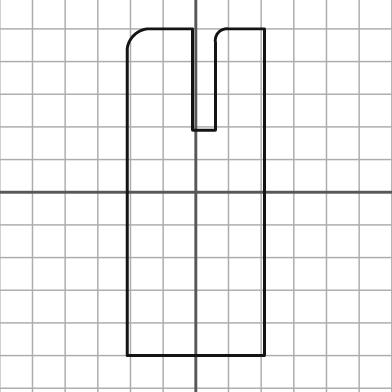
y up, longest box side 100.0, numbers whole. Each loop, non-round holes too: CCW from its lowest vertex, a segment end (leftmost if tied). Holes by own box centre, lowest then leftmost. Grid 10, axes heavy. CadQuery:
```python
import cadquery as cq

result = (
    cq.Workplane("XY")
    .moveTo(-21.0, -50.0)
    .lineTo(21.0, -50.0)
    .lineTo(21.0, 50.0)
    .lineTo(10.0, 50.0)
    .threePointArc((7.0, 49.0), (6.0, 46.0))
    .lineTo(6.0, 19.0)
    .lineTo(-1.0, 19.0)
    .lineTo(-1.0, 50.0)
    .lineTo(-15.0, 50.0)
    .threePointArc((-19.0, 48.0), (-21.0, 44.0))
    .close()
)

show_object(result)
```